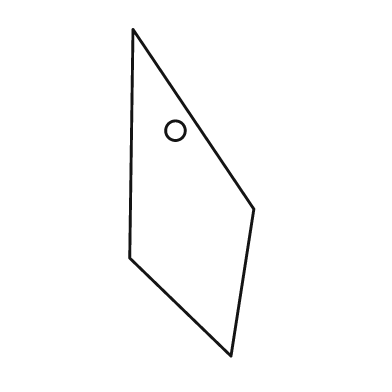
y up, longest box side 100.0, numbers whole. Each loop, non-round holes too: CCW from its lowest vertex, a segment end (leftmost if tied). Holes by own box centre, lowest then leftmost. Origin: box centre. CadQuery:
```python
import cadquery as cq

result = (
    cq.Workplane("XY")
    .moveTo(12.0, -50.0)
    .lineTo(19.0, -5.0)
    .lineTo(-18.0, 50.0)
    .lineTo(-19.0, -20.0)
    .close()
    .moveTo(-5.0, 19.0)
    .circle(3.0)
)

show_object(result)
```